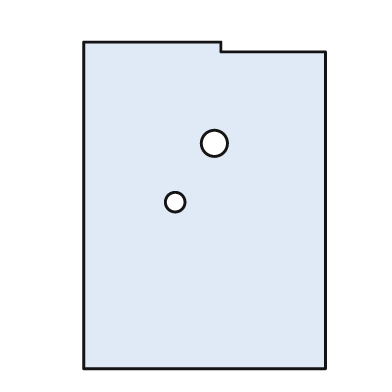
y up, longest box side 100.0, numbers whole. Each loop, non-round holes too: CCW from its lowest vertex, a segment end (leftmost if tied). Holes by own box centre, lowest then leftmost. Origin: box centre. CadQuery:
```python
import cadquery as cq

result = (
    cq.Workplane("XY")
    .moveTo(-37.0, -50.0)
    .lineTo(37.0, -50.0)
    .lineTo(37.0, 47.0)
    .lineTo(5.0, 47.0)
    .lineTo(5.0, 50.0)
    .lineTo(-37.0, 50.0)
    .close()
    .moveTo(-9.0, 1.0)
    .circle(3.0)
    .moveTo(3.0, 19.0)
    .circle(4.0)
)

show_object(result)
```